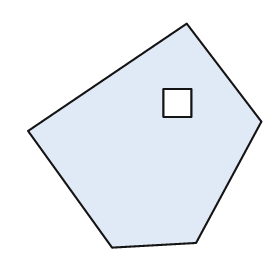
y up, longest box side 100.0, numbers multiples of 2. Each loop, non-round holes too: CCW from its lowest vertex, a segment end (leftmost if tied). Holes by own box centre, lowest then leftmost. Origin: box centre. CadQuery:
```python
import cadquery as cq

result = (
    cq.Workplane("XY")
    .moveTo(-14.0, -48.0)
    .lineTo(22.0, -46.0)
    .lineTo(50.0, 6.0)
    .lineTo(18.0, 48.0)
    .lineTo(-50.0, 2.0)
    .close()
    .moveTo(8.0, 8.0)
    .lineTo(20.0, 8.0)
    .lineTo(20.0, 20.0)
    .lineTo(8.0, 20.0)
    .close()
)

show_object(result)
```